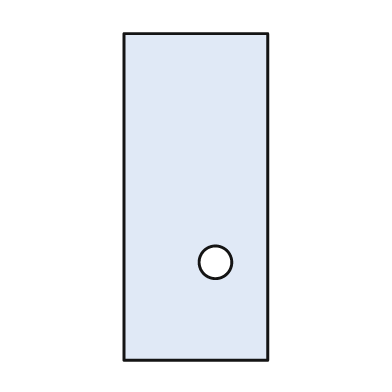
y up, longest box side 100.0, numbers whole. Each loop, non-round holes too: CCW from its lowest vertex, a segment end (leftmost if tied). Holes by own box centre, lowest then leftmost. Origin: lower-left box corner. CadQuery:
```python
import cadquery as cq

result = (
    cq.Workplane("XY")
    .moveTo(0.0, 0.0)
    .lineTo(44.0, 0.0)
    .lineTo(44.0, 100.0)
    .lineTo(0.0, 100.0)
    .close()
    .moveTo(28.0, 30.0)
    .circle(5.0)
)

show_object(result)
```